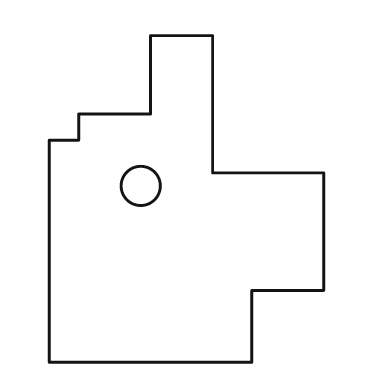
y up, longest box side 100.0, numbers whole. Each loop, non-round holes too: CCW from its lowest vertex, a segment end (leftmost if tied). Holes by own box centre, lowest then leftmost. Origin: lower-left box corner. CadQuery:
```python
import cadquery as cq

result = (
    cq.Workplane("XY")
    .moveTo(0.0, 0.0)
    .lineTo(62.0, 0.0)
    .lineTo(62.0, 22.0)
    .lineTo(84.0, 22.0)
    .lineTo(84.0, 58.0)
    .lineTo(50.0, 58.0)
    .lineTo(50.0, 100.0)
    .lineTo(31.0, 100.0)
    .lineTo(31.0, 76.0)
    .lineTo(9.0, 76.0)
    .lineTo(9.0, 68.0)
    .lineTo(0.0, 68.0)
    .close()
    .moveTo(28.0, 54.0)
    .circle(6.0)
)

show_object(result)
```